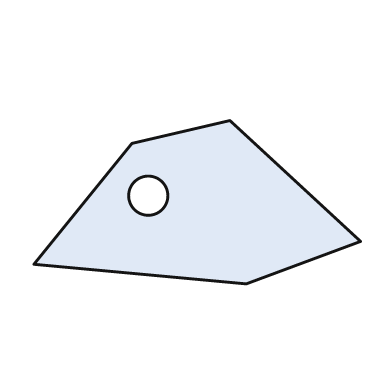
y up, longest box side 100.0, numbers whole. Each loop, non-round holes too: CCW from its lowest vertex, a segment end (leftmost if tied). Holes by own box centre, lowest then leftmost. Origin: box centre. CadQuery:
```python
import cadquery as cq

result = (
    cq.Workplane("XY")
    .moveTo(15.0, -25.0)
    .lineTo(50.0, -12.0)
    .lineTo(10.0, 25.0)
    .lineTo(-20.0, 18.0)
    .lineTo(-50.0, -19.0)
    .close()
    .moveTo(-15.0, 2.0)
    .circle(6.0)
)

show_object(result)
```